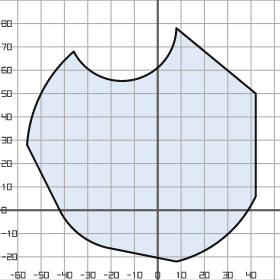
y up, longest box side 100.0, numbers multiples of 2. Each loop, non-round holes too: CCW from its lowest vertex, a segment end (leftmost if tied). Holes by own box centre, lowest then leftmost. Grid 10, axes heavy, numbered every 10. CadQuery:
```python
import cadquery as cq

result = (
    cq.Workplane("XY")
    .moveTo(8.0, -22.0)
    .threePointArc((28.0, -12.0), (42.0, 6.0))
    .lineTo(42.0, 50.0)
    .lineTo(8.0, 78.0)
    .threePointArc((-10.0, 56.0), (-36.0, 68.0))
    .threePointArc((-50.0, 50.0), (-56.0, 28.0))
    .lineTo(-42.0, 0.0)
    .threePointArc((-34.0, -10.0), (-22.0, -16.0))
    .close()
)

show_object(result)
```